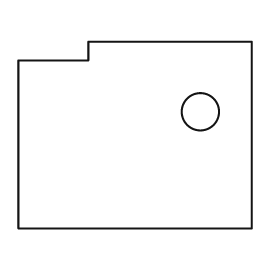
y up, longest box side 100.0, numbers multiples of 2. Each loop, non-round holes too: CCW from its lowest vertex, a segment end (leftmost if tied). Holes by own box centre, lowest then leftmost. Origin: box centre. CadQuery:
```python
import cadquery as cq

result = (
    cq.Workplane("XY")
    .moveTo(-50.0, -40.0)
    .lineTo(50.0, -40.0)
    .lineTo(50.0, 40.0)
    .lineTo(-20.0, 40.0)
    .lineTo(-20.0, 32.0)
    .lineTo(-50.0, 32.0)
    .close()
    .moveTo(28.0, 10.0)
    .circle(8.0)
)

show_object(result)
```